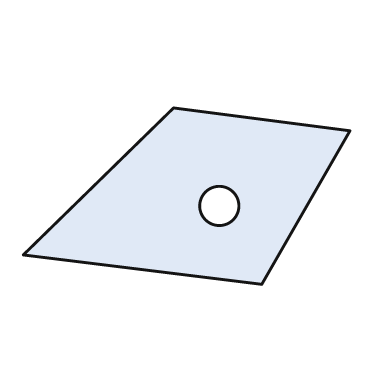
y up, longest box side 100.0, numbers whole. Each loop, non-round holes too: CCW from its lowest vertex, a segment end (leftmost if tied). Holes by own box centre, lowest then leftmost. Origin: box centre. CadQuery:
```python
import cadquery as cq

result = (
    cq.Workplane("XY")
    .moveTo(23.0, -27.0)
    .lineTo(50.0, 20.0)
    .lineTo(-4.0, 27.0)
    .lineTo(-50.0, -18.0)
    .close()
    .moveTo(10.0, -3.0)
    .circle(6.0)
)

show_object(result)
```